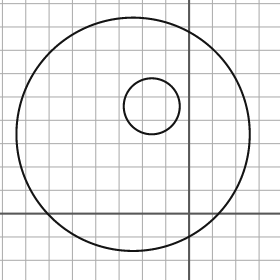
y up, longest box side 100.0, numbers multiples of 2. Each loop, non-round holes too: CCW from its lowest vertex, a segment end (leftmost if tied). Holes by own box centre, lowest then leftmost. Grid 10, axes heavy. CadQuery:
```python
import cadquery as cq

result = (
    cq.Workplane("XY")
    .moveTo(-24.0, 34.0)
    .circle(50.0)
    .moveTo(-16.0, 46.0)
    .circle(12.0)
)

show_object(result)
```